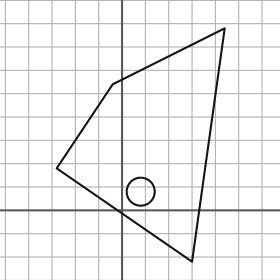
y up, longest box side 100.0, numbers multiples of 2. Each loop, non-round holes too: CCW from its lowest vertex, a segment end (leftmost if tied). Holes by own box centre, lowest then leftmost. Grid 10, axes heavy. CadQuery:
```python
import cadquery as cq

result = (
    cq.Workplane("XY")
    .moveTo(30.0, -22.0)
    .lineTo(44.0, 78.0)
    .lineTo(-4.0, 54.0)
    .lineTo(-28.0, 18.0)
    .close()
    .moveTo(8.0, 8.0)
    .circle(6.0)
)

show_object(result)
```